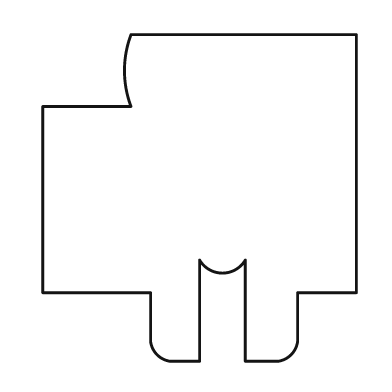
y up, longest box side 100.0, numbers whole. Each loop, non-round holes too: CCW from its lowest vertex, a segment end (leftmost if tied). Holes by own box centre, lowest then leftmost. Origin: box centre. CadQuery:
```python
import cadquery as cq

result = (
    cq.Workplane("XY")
    .moveTo(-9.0, -50.0)
    .lineTo(0.0, -50.0)
    .lineTo(0.0, -19.0)
    .threePointArc((7.0, -23.0), (14.0, -19.0))
    .lineTo(14.0, -50.0)
    .lineTo(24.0, -50.0)
    .threePointArc((28.0, -48.0), (30.0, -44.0))
    .lineTo(30.0, -29.0)
    .lineTo(48.0, -29.0)
    .lineTo(48.0, 50.0)
    .lineTo(-21.0, 50.0)
    .threePointArc((-23.0, 39.0), (-21.0, 28.0))
    .lineTo(-48.0, 28.0)
    .lineTo(-48.0, -29.0)
    .lineTo(-15.0, -29.0)
    .lineTo(-15.0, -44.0)
    .threePointArc((-13.0, -48.0), (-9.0, -50.0))
    .close()
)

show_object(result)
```